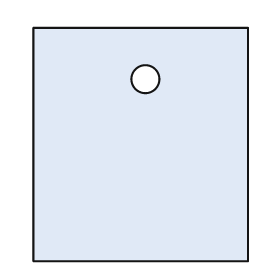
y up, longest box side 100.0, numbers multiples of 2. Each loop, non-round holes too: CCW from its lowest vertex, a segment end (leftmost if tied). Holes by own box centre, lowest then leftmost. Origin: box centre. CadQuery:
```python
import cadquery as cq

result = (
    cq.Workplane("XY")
    .moveTo(-46.0, -50.0)
    .lineTo(46.0, -50.0)
    .lineTo(46.0, 50.0)
    .lineTo(-46.0, 50.0)
    .close()
    .moveTo(2.0, 28.0)
    .circle(6.0)
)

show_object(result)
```